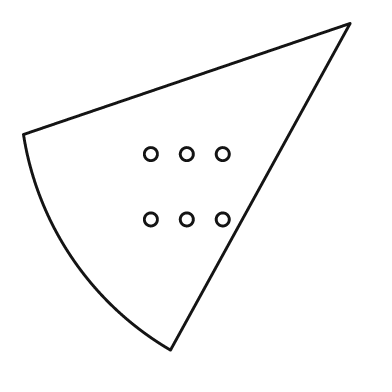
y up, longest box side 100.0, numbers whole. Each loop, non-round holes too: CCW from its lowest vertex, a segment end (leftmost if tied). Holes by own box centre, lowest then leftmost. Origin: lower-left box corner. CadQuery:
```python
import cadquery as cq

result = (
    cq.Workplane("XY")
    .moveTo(45.0, 0.0)
    .lineTo(100.0, 100.0)
    .lineTo(0.0, 66.0)
    .threePointArc((15.0, 28.0), (45.0, 0.0))
    .close()
    .moveTo(39.0, 40.0)
    .circle(2.0)
    .moveTo(50.0, 40.0)
    .circle(2.0)
    .moveTo(61.0, 40.0)
    .circle(2.0)
    .moveTo(39.0, 60.0)
    .circle(2.0)
    .moveTo(50.0, 60.0)
    .circle(2.0)
    .moveTo(61.0, 60.0)
    .circle(2.0)
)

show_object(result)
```